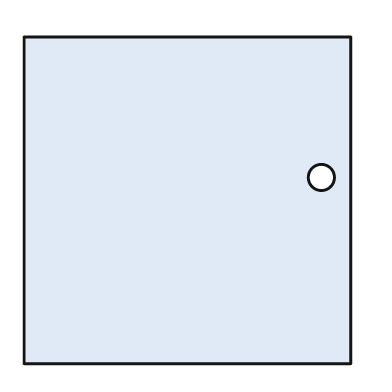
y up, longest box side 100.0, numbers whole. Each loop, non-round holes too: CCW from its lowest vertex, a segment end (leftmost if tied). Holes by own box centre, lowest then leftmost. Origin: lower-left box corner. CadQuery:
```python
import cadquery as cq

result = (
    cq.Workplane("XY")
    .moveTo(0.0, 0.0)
    .lineTo(100.0, 0.0)
    .lineTo(100.0, 100.0)
    .lineTo(0.0, 100.0)
    .close()
    .moveTo(91.0, 57.0)
    .circle(4.0)
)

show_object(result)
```